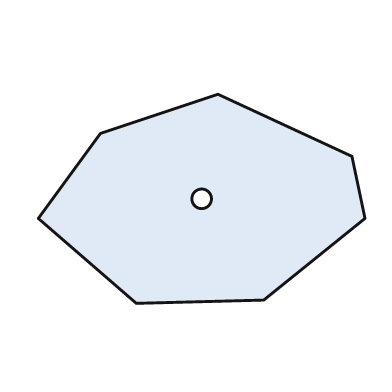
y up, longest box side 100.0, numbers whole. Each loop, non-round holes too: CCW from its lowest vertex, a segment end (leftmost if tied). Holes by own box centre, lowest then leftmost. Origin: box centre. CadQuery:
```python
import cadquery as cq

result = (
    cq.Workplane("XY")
    .moveTo(-20.0, -32.0)
    .lineTo(19.0, -31.0)
    .lineTo(50.0, -6.0)
    .lineTo(46.0, 13.0)
    .lineTo(5.0, 32.0)
    .lineTo(-31.0, 20.0)
    .lineTo(-50.0, -6.0)
    .close()
    .moveTo(0.0, 0.0)
    .circle(3.0)
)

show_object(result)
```